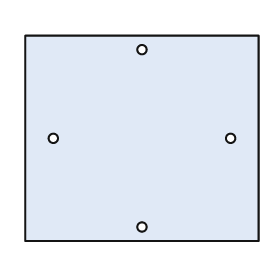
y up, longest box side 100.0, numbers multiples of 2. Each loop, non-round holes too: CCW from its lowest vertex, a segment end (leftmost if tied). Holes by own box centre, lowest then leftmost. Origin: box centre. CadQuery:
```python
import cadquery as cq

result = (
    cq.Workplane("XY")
    .moveTo(-50.0, -44.0)
    .lineTo(50.0, -44.0)
    .lineTo(50.0, 44.0)
    .lineTo(-50.0, 44.0)
    .close()
    .moveTo(0.0, -38.0)
    .circle(2.0)
    .moveTo(-38.0, 0.0)
    .circle(2.0)
    .moveTo(38.0, 0.0)
    .circle(2.0)
    .moveTo(0.0, 38.0)
    .circle(2.0)
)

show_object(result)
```